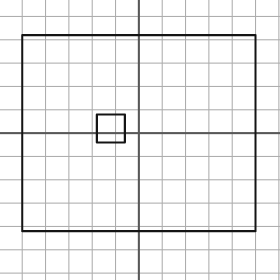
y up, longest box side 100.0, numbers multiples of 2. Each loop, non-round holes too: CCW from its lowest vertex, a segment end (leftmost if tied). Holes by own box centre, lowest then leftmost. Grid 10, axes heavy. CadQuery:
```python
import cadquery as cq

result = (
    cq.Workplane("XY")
    .moveTo(-50.0, -42.0)
    .lineTo(50.0, -42.0)
    .lineTo(50.0, 42.0)
    .lineTo(-50.0, 42.0)
    .close()
    .moveTo(-18.0, -4.0)
    .lineTo(-6.0, -4.0)
    .lineTo(-6.0, 8.0)
    .lineTo(-18.0, 8.0)
    .close()
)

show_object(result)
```